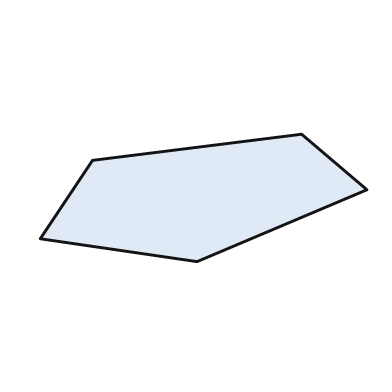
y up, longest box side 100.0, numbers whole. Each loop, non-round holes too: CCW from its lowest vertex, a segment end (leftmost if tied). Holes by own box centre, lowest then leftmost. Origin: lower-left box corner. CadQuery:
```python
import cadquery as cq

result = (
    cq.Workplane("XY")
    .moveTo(48.0, 0.0)
    .lineTo(100.0, 22.0)
    .lineTo(80.0, 39.0)
    .lineTo(16.0, 31.0)
    .lineTo(0.0, 7.0)
    .close()
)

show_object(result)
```